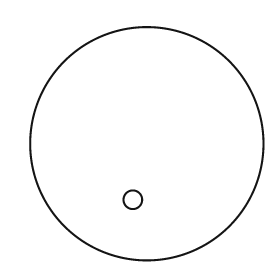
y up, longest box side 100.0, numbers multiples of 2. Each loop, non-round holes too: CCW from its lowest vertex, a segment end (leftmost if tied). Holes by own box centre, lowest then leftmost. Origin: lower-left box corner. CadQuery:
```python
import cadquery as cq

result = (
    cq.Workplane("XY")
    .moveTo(50.0, 50.0)
    .circle(50.0)
    .moveTo(44.0, 26.0)
    .circle(4.0)
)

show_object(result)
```